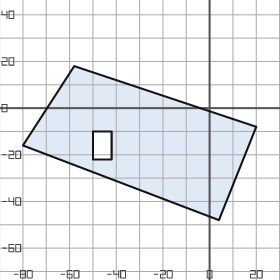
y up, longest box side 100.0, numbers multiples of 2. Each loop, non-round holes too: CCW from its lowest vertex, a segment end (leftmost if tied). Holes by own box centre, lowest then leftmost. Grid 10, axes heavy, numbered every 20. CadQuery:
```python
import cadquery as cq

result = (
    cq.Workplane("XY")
    .moveTo(4.0, -48.0)
    .lineTo(20.0, -8.0)
    .lineTo(-58.0, 18.0)
    .lineTo(-80.0, -16.0)
    .close()
    .moveTo(-50.0, -22.0)
    .lineTo(-42.0, -22.0)
    .lineTo(-42.0, -10.0)
    .lineTo(-50.0, -10.0)
    .close()
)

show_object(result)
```